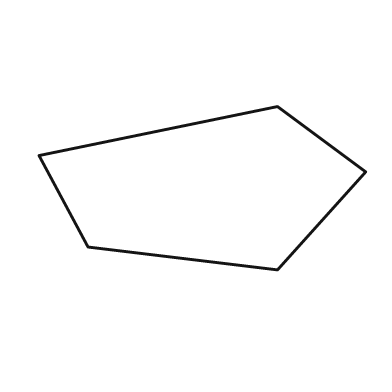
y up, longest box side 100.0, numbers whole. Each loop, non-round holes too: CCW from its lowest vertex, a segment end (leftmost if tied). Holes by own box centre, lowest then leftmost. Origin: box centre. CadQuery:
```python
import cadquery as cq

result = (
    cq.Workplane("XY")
    .moveTo(23.0, -25.0)
    .lineTo(50.0, 5.0)
    .lineTo(23.0, 25.0)
    .lineTo(-50.0, 10.0)
    .lineTo(-35.0, -18.0)
    .close()
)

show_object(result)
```